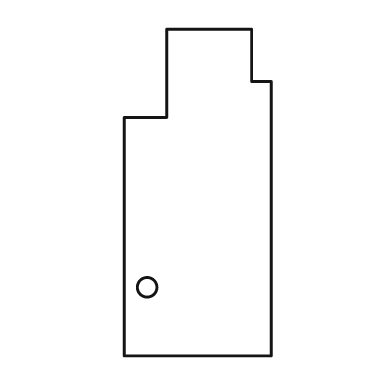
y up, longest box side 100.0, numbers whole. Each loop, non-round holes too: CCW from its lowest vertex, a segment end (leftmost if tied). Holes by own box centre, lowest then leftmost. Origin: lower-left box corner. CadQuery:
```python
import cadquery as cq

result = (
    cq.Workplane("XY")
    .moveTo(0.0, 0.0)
    .lineTo(45.0, 0.0)
    .lineTo(45.0, 84.0)
    .lineTo(39.0, 84.0)
    .lineTo(39.0, 100.0)
    .lineTo(13.0, 100.0)
    .lineTo(13.0, 73.0)
    .lineTo(0.0, 73.0)
    .close()
    .moveTo(7.0, 21.0)
    .circle(3.0)
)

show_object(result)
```